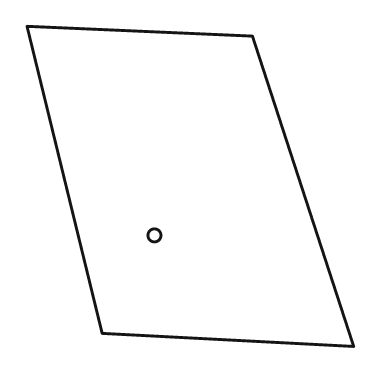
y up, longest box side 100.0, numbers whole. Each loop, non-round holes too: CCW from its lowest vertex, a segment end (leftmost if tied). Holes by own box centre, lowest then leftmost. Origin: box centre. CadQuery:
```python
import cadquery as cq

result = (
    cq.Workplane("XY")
    .moveTo(50.0, -49.0)
    .lineTo(19.0, 46.0)
    .lineTo(-50.0, 49.0)
    .lineTo(-27.0, -45.0)
    .close()
    .moveTo(-11.0, -15.0)
    .circle(2.0)
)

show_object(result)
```